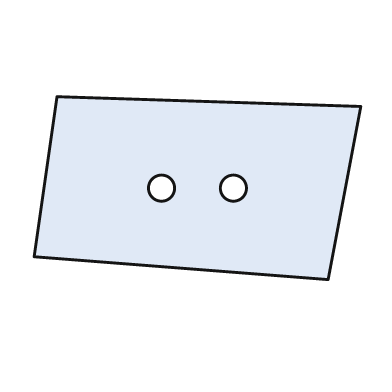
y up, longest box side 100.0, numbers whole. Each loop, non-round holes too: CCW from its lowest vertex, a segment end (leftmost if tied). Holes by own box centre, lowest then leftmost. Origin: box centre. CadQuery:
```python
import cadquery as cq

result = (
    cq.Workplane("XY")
    .moveTo(40.0, -28.0)
    .lineTo(50.0, 25.0)
    .lineTo(-43.0, 28.0)
    .lineTo(-50.0, -21.0)
    .close()
    .moveTo(-11.0, 0.0)
    .circle(4.0)
    .moveTo(11.0, 0.0)
    .circle(4.0)
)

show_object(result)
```